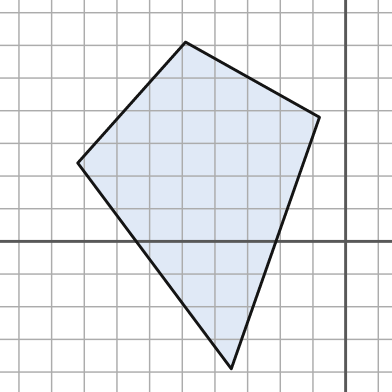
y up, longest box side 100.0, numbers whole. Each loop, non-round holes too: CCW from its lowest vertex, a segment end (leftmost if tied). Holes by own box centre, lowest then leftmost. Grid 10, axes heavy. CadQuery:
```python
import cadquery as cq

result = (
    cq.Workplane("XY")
    .moveTo(-35.0, -39.0)
    .lineTo(-8.0, 38.0)
    .lineTo(-49.0, 61.0)
    .lineTo(-82.0, 24.0)
    .close()
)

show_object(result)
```